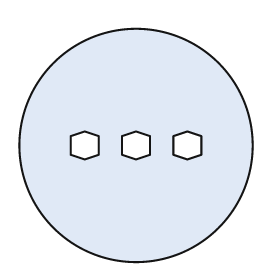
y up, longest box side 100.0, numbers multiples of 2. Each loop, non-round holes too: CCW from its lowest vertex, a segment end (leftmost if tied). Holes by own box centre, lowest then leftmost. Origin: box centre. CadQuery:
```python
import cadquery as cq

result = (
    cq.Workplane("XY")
    .moveTo(0.0, 0.0)
    .circle(50.0)
    .moveTo(-22.0, -6.0)
    .lineTo(-16.0, -4.0)
    .lineTo(-16.0, 4.0)
    .lineTo(-22.0, 6.0)
    .lineTo(-28.0, 4.0)
    .lineTo(-28.0, -4.0)
    .close()
    .moveTo(0.0, -6.0)
    .lineTo(6.0, -4.0)
    .lineTo(6.0, 4.0)
    .lineTo(0.0, 6.0)
    .lineTo(-6.0, 4.0)
    .lineTo(-6.0, -4.0)
    .close()
    .moveTo(22.0, -6.0)
    .lineTo(28.0, -4.0)
    .lineTo(28.0, 4.0)
    .lineTo(22.0, 6.0)
    .lineTo(16.0, 4.0)
    .lineTo(16.0, -4.0)
    .close()
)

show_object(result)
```